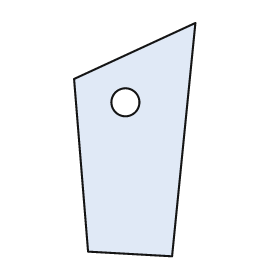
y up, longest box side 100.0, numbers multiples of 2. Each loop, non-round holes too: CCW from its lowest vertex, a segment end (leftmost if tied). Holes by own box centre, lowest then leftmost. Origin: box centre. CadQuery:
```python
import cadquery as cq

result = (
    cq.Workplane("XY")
    .moveTo(16.0, -50.0)
    .lineTo(26.0, 50.0)
    .lineTo(-26.0, 26.0)
    .lineTo(-20.0, -48.0)
    .close()
    .moveTo(-4.0, 16.0)
    .circle(6.0)
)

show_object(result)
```